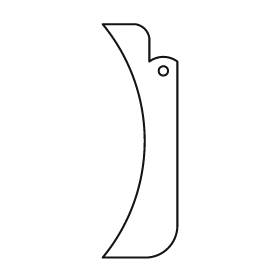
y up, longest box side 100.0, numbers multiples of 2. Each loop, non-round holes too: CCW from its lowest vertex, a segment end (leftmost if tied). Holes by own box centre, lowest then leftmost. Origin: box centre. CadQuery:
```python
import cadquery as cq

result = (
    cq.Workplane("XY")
    .moveTo(-16.0, -50.0)
    .lineTo(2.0, -50.0)
    .threePointArc((12.0, -46.0), (16.0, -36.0))
    .lineTo(16.0, 34.0)
    .threePointArc((10.0, 36.0), (4.0, 34.0))
    .lineTo(4.0, 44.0)
    .threePointArc((2.0, 48.0), (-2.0, 50.0))
    .lineTo(-16.0, 50.0)
    .threePointArc((2.0, 0.0), (-16.0, -50.0))
    .close()
    .moveTo(10.0, 30.0)
    .circle(2.0)
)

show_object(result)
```